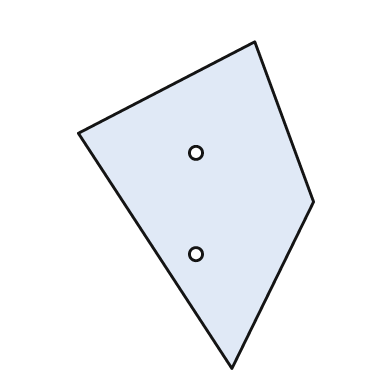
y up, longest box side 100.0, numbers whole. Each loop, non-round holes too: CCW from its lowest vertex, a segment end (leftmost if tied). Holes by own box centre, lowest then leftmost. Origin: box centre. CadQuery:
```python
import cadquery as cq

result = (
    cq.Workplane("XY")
    .moveTo(11.0, -50.0)
    .lineTo(36.0, 1.0)
    .lineTo(18.0, 50.0)
    .lineTo(-36.0, 22.0)
    .close()
    .moveTo(0.0, -15.0)
    .circle(2.0)
    .moveTo(0.0, 16.0)
    .circle(2.0)
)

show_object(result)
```